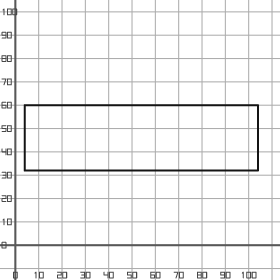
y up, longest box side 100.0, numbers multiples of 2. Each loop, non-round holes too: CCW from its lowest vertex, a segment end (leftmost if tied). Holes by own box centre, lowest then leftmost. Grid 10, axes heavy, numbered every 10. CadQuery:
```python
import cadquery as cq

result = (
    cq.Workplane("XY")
    .moveTo(4.0, 32.0)
    .lineTo(104.0, 32.0)
    .lineTo(104.0, 60.0)
    .lineTo(4.0, 60.0)
    .close()
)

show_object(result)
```